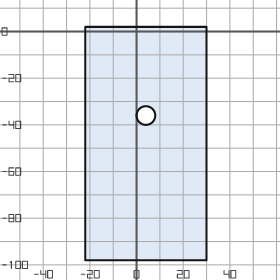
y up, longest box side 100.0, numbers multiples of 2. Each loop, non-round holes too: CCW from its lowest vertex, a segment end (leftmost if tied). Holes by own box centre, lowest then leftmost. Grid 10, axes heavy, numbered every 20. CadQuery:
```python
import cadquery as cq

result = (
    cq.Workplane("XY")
    .moveTo(-22.0, -98.0)
    .lineTo(30.0, -98.0)
    .lineTo(30.0, 2.0)
    .lineTo(-22.0, 2.0)
    .close()
    .moveTo(4.0, -36.0)
    .circle(4.0)
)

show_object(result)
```